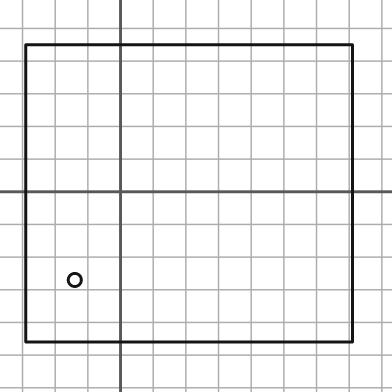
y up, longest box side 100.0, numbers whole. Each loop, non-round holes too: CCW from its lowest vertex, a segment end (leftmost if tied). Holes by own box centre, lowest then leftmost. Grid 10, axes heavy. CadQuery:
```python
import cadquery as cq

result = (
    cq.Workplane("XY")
    .moveTo(-29.0, -46.0)
    .lineTo(71.0, -46.0)
    .lineTo(71.0, 45.0)
    .lineTo(-29.0, 45.0)
    .close()
    .moveTo(-14.0, -27.0)
    .circle(2.0)
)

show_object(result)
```